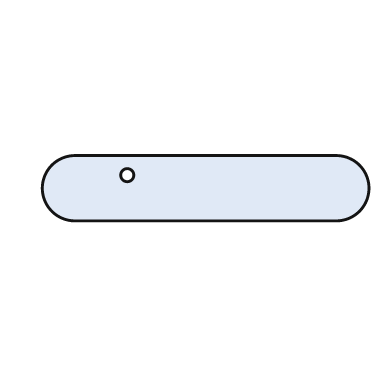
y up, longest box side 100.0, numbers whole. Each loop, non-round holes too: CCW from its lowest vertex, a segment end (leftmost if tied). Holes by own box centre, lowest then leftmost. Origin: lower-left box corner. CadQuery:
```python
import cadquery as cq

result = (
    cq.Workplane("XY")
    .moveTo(10.0, 0.0)
    .lineTo(90.0, 0.0)
    .threePointArc((100.0, 10.0), (90.0, 20.0))
    .lineTo(10.0, 20.0)
    .threePointArc((0.0, 10.0), (10.0, 0.0))
    .close()
    .moveTo(26.0, 14.0)
    .circle(2.0)
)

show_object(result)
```